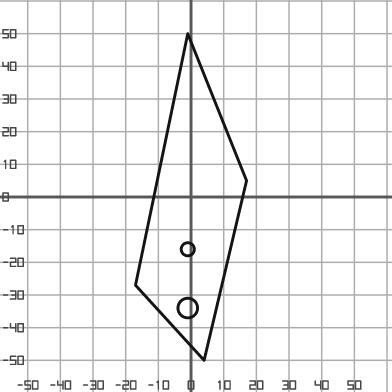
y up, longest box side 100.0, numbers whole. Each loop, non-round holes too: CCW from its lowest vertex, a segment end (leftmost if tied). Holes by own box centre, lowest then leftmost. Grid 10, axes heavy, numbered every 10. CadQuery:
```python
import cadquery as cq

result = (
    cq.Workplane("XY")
    .moveTo(4.0, -50.0)
    .lineTo(17.0, 5.0)
    .lineTo(-1.0, 50.0)
    .lineTo(-17.0, -27.0)
    .close()
    .moveTo(-1.0, -34.0)
    .circle(3.0)
    .moveTo(-1.0, -16.0)
    .circle(2.0)
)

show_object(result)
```